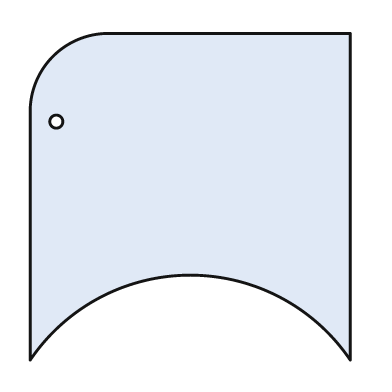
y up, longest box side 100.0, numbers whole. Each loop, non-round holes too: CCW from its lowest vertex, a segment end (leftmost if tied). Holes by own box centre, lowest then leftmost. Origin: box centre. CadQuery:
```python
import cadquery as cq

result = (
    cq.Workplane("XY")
    .moveTo(-49.0, -50.0)
    .threePointArc((0.0, -24.0), (49.0, -50.0))
    .lineTo(49.0, 50.0)
    .lineTo(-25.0, 50.0)
    .threePointArc((-42.0, 43.0), (-49.0, 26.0))
    .close()
    .moveTo(-41.0, 23.0)
    .circle(2.0)
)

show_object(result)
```